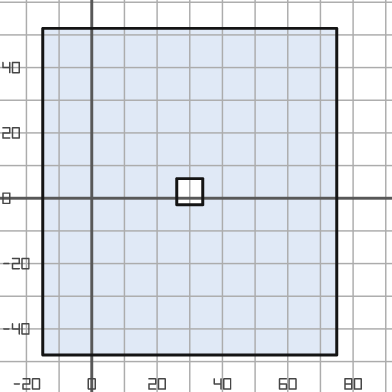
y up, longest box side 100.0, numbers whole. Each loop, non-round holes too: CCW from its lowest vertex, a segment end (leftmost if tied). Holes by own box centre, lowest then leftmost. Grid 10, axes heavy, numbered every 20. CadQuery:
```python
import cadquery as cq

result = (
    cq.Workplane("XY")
    .moveTo(-15.0, -48.0)
    .lineTo(75.0, -48.0)
    .lineTo(75.0, 52.0)
    .lineTo(-15.0, 52.0)
    .close()
    .moveTo(26.0, -2.0)
    .lineTo(34.0, -2.0)
    .lineTo(34.0, 6.0)
    .lineTo(26.0, 6.0)
    .close()
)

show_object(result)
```